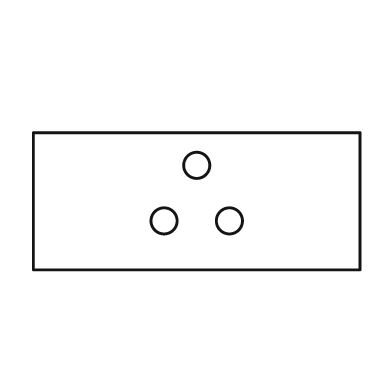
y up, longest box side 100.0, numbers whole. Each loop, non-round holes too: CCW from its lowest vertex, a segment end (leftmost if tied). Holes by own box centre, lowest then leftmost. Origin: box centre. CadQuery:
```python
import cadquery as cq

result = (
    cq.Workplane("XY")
    .moveTo(-50.0, -21.0)
    .lineTo(50.0, -21.0)
    .lineTo(50.0, 21.0)
    .lineTo(-50.0, 21.0)
    .close()
    .moveTo(-10.0, -6.0)
    .circle(4.0)
    .moveTo(10.0, -6.0)
    .circle(4.0)
    .moveTo(0.0, 11.0)
    .circle(4.0)
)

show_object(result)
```